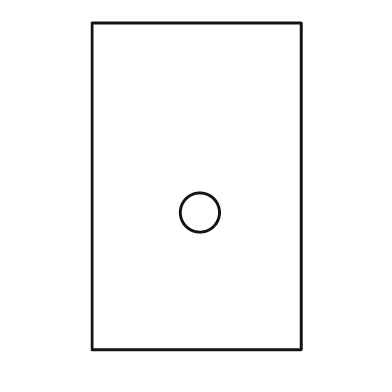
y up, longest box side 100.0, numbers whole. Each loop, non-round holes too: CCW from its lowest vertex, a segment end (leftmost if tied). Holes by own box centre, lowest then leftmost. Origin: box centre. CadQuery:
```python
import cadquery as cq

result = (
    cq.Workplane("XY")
    .moveTo(-32.0, -50.0)
    .lineTo(32.0, -50.0)
    .lineTo(32.0, 50.0)
    .lineTo(-32.0, 50.0)
    .close()
    .moveTo(1.0, -8.0)
    .circle(6.0)
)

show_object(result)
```